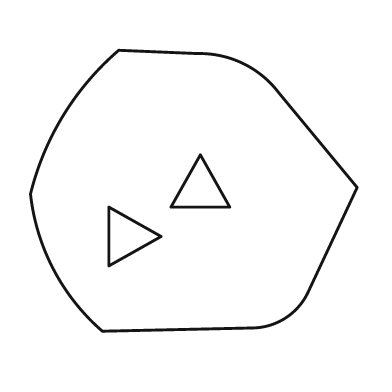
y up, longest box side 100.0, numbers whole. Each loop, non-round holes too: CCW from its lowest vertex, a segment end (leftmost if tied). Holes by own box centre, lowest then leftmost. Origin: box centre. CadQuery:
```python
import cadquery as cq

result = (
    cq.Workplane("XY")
    .moveTo(-28.0, -43.0)
    .lineTo(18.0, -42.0)
    .threePointArc((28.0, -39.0), (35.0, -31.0))
    .lineTo(50.0, 1.0)
    .lineTo(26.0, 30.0)
    .threePointArc((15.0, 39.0), (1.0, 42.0))
    .lineTo(-23.0, 43.0)
    .threePointArc((-40.0, 23.0), (-50.0, -1.0))
    .threePointArc((-43.0, -24.0), (-28.0, -43.0))
    .close()
    .moveTo(-26.0, -23.0)
    .lineTo(-10.0, -14.0)
    .lineTo(-26.0, -5.0)
    .close()
    .moveTo(-7.0, -5.0)
    .lineTo(11.0, -5.0)
    .lineTo(2.0, 11.0)
    .close()
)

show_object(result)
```